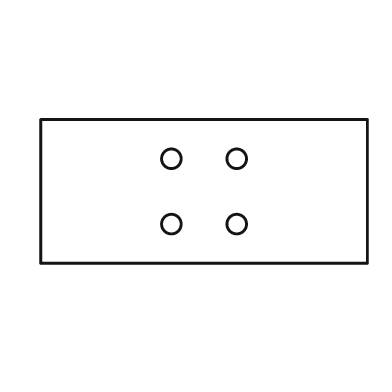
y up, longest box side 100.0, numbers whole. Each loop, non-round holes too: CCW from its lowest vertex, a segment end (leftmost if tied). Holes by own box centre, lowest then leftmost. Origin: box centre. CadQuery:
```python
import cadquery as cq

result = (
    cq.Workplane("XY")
    .moveTo(-50.0, -22.0)
    .lineTo(50.0, -22.0)
    .lineTo(50.0, 22.0)
    .lineTo(-50.0, 22.0)
    .close()
    .moveTo(-10.0, -10.0)
    .circle(3.0)
    .moveTo(10.0, -10.0)
    .circle(3.0)
    .moveTo(-10.0, 10.0)
    .circle(3.0)
    .moveTo(10.0, 10.0)
    .circle(3.0)
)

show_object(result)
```